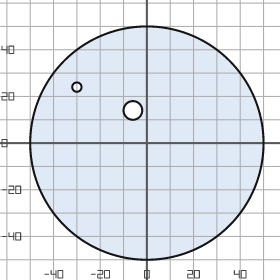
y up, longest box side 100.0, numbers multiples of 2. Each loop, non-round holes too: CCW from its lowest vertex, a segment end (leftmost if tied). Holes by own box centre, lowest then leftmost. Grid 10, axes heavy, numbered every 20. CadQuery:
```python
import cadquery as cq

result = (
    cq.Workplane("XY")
    .moveTo(0.0, 0.0)
    .circle(50.0)
    .moveTo(-6.0, 14.0)
    .circle(4.0)
    .moveTo(-30.0, 24.0)
    .circle(2.0)
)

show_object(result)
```